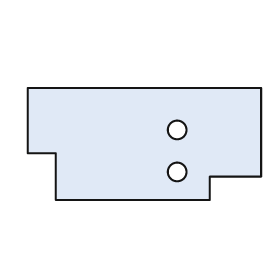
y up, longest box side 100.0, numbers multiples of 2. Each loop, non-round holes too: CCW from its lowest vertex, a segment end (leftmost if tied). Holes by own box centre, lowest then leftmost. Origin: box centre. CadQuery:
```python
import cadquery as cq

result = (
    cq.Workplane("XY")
    .moveTo(-38.0, -24.0)
    .lineTo(28.0, -24.0)
    .lineTo(28.0, -14.0)
    .lineTo(50.0, -14.0)
    .lineTo(50.0, 24.0)
    .lineTo(-50.0, 24.0)
    .lineTo(-50.0, -4.0)
    .lineTo(-38.0, -4.0)
    .close()
    .moveTo(14.0, -12.0)
    .circle(4.0)
    .moveTo(14.0, 6.0)
    .circle(4.0)
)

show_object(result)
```